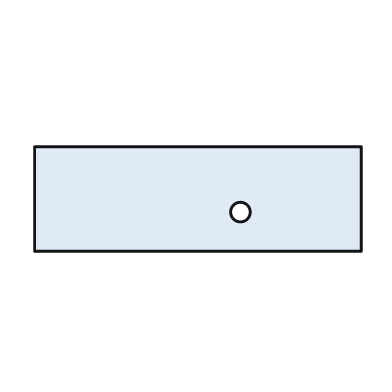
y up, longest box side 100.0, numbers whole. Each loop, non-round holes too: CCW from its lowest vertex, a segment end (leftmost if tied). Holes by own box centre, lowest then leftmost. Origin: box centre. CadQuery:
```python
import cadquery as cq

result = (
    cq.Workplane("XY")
    .moveTo(-50.0, -16.0)
    .lineTo(50.0, -16.0)
    .lineTo(50.0, 16.0)
    .lineTo(-50.0, 16.0)
    .close()
    .moveTo(13.0, -4.0)
    .circle(3.0)
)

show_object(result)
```